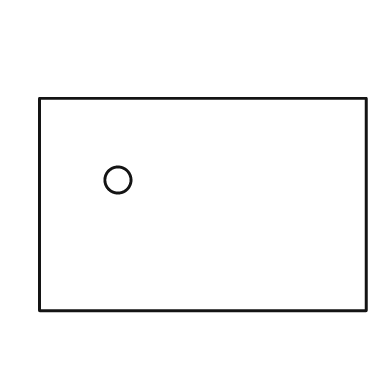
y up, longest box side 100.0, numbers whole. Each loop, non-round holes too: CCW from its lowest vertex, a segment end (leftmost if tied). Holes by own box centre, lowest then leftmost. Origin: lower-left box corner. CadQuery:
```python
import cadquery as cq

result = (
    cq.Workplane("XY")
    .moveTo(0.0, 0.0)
    .lineTo(100.0, 0.0)
    .lineTo(100.0, 65.0)
    .lineTo(0.0, 65.0)
    .close()
    .moveTo(24.0, 40.0)
    .circle(4.0)
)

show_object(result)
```